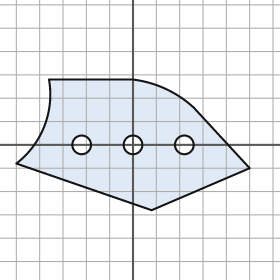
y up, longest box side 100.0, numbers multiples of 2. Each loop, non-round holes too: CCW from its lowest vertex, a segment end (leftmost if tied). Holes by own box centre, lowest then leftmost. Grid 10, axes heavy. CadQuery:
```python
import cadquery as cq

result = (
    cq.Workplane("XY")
    .moveTo(8.0, -28.0)
    .lineTo(50.0, -10.0)
    .lineTo(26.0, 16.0)
    .threePointArc((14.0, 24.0), (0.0, 28.0))
    .lineTo(-36.0, 28.0)
    .threePointArc((-38.0, 8.0), (-50.0, -8.0))
    .close()
    .moveTo(-22.0, 0.0)
    .circle(4.0)
    .moveTo(0.0, 0.0)
    .circle(4.0)
    .moveTo(22.0, 0.0)
    .circle(4.0)
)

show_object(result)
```